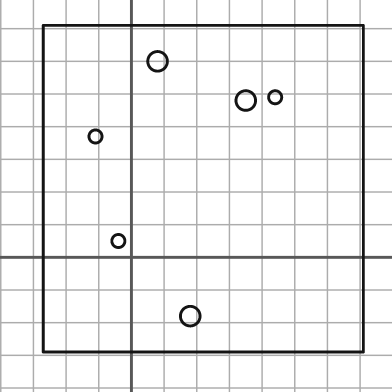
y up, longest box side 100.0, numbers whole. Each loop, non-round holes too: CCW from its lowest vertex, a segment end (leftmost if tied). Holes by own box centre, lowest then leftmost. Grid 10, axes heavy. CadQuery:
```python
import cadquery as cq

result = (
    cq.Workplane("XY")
    .moveTo(-27.0, -29.0)
    .lineTo(71.0, -29.0)
    .lineTo(71.0, 71.0)
    .lineTo(-27.0, 71.0)
    .close()
    .moveTo(18.0, -18.0)
    .circle(3.0)
    .moveTo(-4.0, 5.0)
    .circle(2.0)
    .moveTo(-11.0, 37.0)
    .circle(2.0)
    .moveTo(35.0, 48.0)
    .circle(3.0)
    .moveTo(44.0, 49.0)
    .circle(2.0)
    .moveTo(8.0, 60.0)
    .circle(3.0)
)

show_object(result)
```